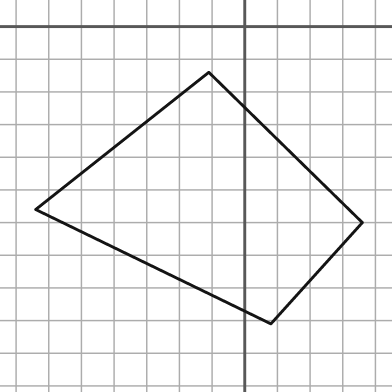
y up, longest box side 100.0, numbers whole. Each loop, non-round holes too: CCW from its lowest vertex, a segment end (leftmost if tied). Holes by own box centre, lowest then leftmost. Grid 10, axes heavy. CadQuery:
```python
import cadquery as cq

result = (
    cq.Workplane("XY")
    .moveTo(8.0, -91.0)
    .lineTo(36.0, -60.0)
    .lineTo(-11.0, -14.0)
    .lineTo(-64.0, -56.0)
    .close()
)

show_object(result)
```